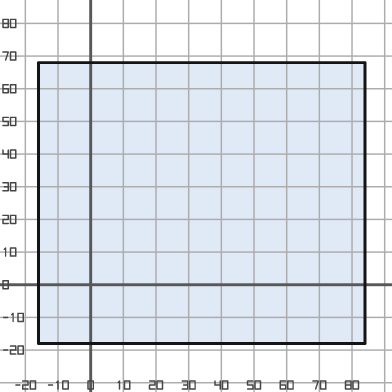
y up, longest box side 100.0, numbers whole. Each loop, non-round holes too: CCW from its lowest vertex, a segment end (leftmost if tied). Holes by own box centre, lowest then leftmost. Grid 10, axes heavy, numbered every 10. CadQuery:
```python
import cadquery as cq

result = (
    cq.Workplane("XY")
    .moveTo(-16.0, -18.0)
    .lineTo(84.0, -18.0)
    .lineTo(84.0, 68.0)
    .lineTo(-16.0, 68.0)
    .close()
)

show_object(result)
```